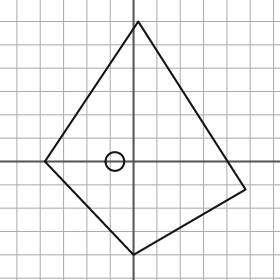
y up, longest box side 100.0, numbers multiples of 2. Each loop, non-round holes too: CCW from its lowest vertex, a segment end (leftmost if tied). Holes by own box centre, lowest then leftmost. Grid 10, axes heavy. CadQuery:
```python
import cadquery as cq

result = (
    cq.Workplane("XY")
    .moveTo(0.0, -40.0)
    .lineTo(48.0, -12.0)
    .lineTo(2.0, 60.0)
    .lineTo(-38.0, 0.0)
    .close()
    .moveTo(-8.0, 0.0)
    .circle(4.0)
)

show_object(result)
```